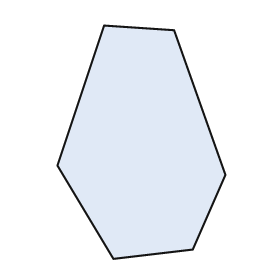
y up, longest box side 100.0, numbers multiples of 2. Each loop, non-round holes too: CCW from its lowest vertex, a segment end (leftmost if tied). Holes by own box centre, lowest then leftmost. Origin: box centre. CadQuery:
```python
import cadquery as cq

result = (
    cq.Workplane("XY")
    .moveTo(-12.0, -50.0)
    .lineTo(22.0, -46.0)
    .lineTo(36.0, -14.0)
    .lineTo(14.0, 48.0)
    .lineTo(-16.0, 50.0)
    .lineTo(-36.0, -10.0)
    .close()
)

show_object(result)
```